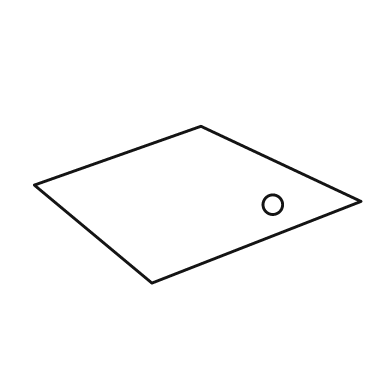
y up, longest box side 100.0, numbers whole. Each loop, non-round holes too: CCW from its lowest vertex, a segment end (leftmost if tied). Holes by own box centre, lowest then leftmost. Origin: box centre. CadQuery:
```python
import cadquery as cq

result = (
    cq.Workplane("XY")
    .moveTo(-14.0, -24.0)
    .lineTo(50.0, 1.0)
    .lineTo(1.0, 24.0)
    .lineTo(-50.0, 6.0)
    .close()
    .moveTo(23.0, 0.0)
    .circle(3.0)
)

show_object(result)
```